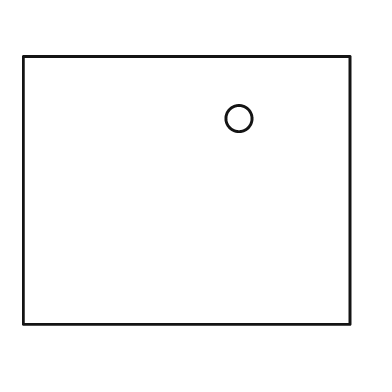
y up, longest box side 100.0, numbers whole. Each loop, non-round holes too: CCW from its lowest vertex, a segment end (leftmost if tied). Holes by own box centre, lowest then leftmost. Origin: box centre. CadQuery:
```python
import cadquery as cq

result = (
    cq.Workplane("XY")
    .moveTo(-50.0, -41.0)
    .lineTo(50.0, -41.0)
    .lineTo(50.0, 41.0)
    .lineTo(-50.0, 41.0)
    .close()
    .moveTo(16.0, 22.0)
    .circle(4.0)
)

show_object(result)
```